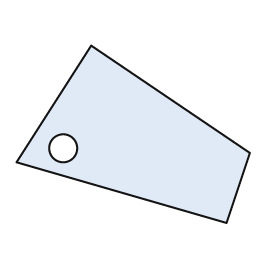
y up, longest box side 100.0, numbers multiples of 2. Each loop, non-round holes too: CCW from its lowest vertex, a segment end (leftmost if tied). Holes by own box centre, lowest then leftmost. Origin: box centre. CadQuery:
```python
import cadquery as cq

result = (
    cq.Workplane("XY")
    .moveTo(40.0, -38.0)
    .lineTo(50.0, -8.0)
    .lineTo(-18.0, 38.0)
    .lineTo(-50.0, -12.0)
    .close()
    .moveTo(-30.0, -6.0)
    .circle(6.0)
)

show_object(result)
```